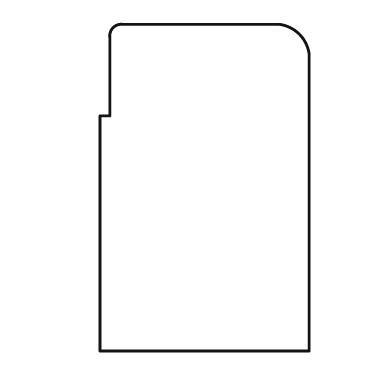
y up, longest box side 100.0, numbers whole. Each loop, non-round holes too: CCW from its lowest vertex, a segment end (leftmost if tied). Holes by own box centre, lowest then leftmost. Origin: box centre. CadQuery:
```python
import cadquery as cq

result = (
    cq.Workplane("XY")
    .moveTo(-32.0, -50.0)
    .lineTo(32.0, -50.0)
    .lineTo(32.0, 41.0)
    .threePointArc((29.0, 47.0), (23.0, 50.0))
    .lineTo(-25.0, 50.0)
    .threePointArc((-28.0, 49.0), (-29.0, 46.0))
    .lineTo(-29.0, 22.0)
    .lineTo(-32.0, 22.0)
    .close()
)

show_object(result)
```